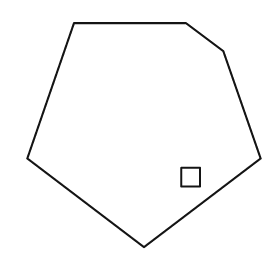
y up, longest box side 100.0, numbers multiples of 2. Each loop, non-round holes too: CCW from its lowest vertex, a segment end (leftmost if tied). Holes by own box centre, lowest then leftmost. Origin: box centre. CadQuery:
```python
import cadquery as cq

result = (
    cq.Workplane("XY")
    .moveTo(0.0, -48.0)
    .lineTo(50.0, -10.0)
    .lineTo(34.0, 36.0)
    .lineTo(18.0, 48.0)
    .lineTo(-30.0, 48.0)
    .lineTo(-50.0, -10.0)
    .close()
    .moveTo(16.0, -22.0)
    .lineTo(24.0, -22.0)
    .lineTo(24.0, -14.0)
    .lineTo(16.0, -14.0)
    .close()
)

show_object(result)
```